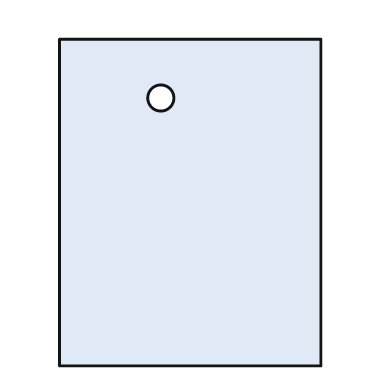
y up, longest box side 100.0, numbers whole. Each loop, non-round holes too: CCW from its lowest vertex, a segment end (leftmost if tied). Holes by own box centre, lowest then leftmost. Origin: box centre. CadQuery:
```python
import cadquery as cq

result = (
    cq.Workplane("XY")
    .moveTo(-40.0, -50.0)
    .lineTo(40.0, -50.0)
    .lineTo(40.0, 50.0)
    .lineTo(-40.0, 50.0)
    .close()
    .moveTo(-9.0, 32.0)
    .circle(4.0)
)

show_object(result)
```